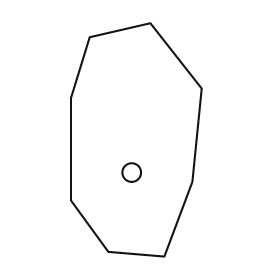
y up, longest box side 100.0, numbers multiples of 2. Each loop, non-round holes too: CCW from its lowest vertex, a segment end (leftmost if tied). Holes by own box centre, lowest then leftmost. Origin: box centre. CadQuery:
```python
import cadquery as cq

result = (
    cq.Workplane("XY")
    .moveTo(12.0, -50.0)
    .lineTo(24.0, -18.0)
    .lineTo(28.0, 22.0)
    .lineTo(6.0, 50.0)
    .lineTo(-20.0, 44.0)
    .lineTo(-28.0, 18.0)
    .lineTo(-28.0, -26.0)
    .lineTo(-12.0, -48.0)
    .close()
    .moveTo(-2.0, -14.0)
    .circle(4.0)
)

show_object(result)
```